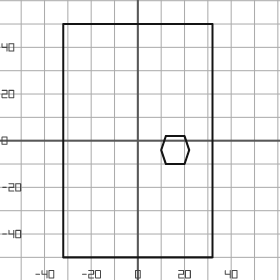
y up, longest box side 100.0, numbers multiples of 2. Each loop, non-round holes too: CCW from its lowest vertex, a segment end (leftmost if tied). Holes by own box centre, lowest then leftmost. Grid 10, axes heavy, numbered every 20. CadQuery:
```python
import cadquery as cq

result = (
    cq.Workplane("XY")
    .moveTo(-32.0, -50.0)
    .lineTo(32.0, -50.0)
    .lineTo(32.0, 50.0)
    .lineTo(-32.0, 50.0)
    .close()
    .moveTo(12.0, -10.0)
    .lineTo(20.0, -10.0)
    .lineTo(22.0, -4.0)
    .lineTo(20.0, 2.0)
    .lineTo(12.0, 2.0)
    .lineTo(10.0, -4.0)
    .close()
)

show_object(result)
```